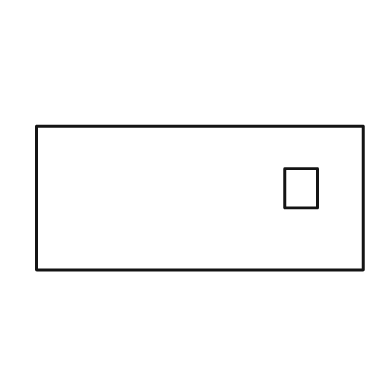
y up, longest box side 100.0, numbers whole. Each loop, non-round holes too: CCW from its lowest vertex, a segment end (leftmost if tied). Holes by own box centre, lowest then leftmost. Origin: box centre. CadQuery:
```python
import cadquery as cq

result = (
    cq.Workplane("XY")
    .moveTo(-50.0, -22.0)
    .lineTo(50.0, -22.0)
    .lineTo(50.0, 22.0)
    .lineTo(-50.0, 22.0)
    .close()
    .moveTo(26.0, -3.0)
    .lineTo(36.0, -3.0)
    .lineTo(36.0, 9.0)
    .lineTo(26.0, 9.0)
    .close()
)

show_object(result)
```